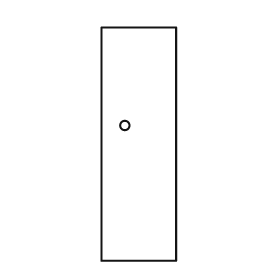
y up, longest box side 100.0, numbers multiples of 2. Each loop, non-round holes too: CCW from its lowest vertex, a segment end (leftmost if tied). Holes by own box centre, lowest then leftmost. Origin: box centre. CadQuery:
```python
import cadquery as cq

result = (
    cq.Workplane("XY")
    .moveTo(-16.0, -50.0)
    .lineTo(16.0, -50.0)
    .lineTo(16.0, 50.0)
    .lineTo(-16.0, 50.0)
    .close()
    .moveTo(-6.0, 8.0)
    .circle(2.0)
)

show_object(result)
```